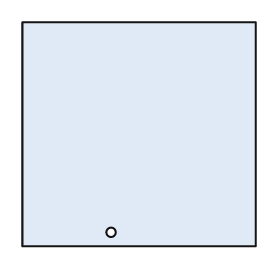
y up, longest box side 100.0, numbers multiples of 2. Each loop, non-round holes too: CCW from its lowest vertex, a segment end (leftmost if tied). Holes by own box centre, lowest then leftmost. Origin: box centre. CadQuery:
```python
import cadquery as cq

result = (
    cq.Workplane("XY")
    .moveTo(-50.0, -48.0)
    .lineTo(50.0, -48.0)
    .lineTo(50.0, 48.0)
    .lineTo(-50.0, 48.0)
    .close()
    .moveTo(-12.0, -42.0)
    .circle(2.0)
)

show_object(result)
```